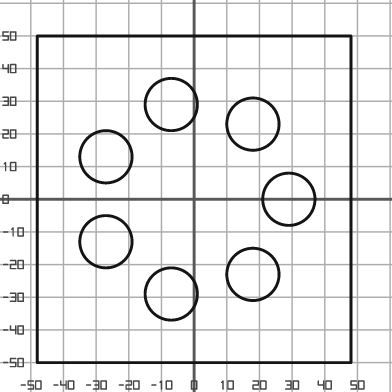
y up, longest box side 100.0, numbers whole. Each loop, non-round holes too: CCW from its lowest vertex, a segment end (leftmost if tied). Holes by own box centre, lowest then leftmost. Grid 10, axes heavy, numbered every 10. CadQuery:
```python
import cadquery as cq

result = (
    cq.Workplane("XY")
    .moveTo(-48.0, -50.0)
    .lineTo(48.0, -50.0)
    .lineTo(48.0, 50.0)
    .lineTo(-48.0, 50.0)
    .close()
    .moveTo(-7.0, -29.0)
    .circle(8.0)
    .moveTo(18.0, -23.0)
    .circle(8.0)
    .moveTo(-27.0, -13.0)
    .circle(8.0)
    .moveTo(29.0, 0.0)
    .circle(8.0)
    .moveTo(-27.0, 13.0)
    .circle(8.0)
    .moveTo(18.0, 23.0)
    .circle(8.0)
    .moveTo(-7.0, 29.0)
    .circle(8.0)
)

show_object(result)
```